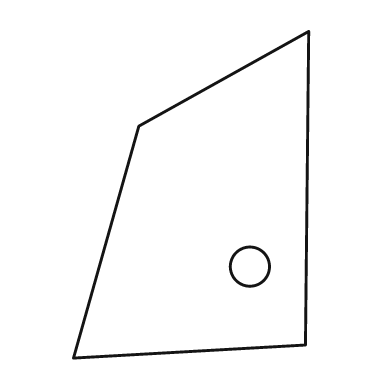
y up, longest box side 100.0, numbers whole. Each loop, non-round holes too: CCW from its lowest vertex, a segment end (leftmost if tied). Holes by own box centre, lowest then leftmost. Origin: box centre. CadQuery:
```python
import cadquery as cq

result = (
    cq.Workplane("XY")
    .moveTo(-36.0, -50.0)
    .lineTo(35.0, -46.0)
    .lineTo(36.0, 50.0)
    .lineTo(-16.0, 21.0)
    .close()
    .moveTo(18.0, -22.0)
    .circle(6.0)
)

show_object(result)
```